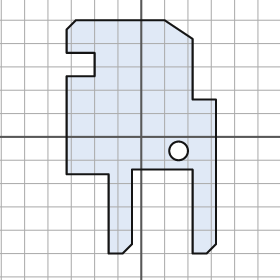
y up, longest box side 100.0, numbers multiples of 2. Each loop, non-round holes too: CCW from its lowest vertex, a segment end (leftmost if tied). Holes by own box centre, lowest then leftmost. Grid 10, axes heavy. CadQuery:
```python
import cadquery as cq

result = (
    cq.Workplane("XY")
    .moveTo(-14.0, -50.0)
    .lineTo(-8.0, -50.0)
    .lineTo(-4.0, -46.0)
    .lineTo(-4.0, -14.0)
    .lineTo(22.0, -14.0)
    .lineTo(22.0, -50.0)
    .lineTo(28.0, -50.0)
    .lineTo(32.0, -46.0)
    .lineTo(32.0, 16.0)
    .lineTo(22.0, 16.0)
    .lineTo(22.0, 42.0)
    .lineTo(10.0, 50.0)
    .lineTo(-28.0, 50.0)
    .lineTo(-32.0, 46.0)
    .lineTo(-32.0, 36.0)
    .lineTo(-20.0, 36.0)
    .lineTo(-20.0, 26.0)
    .lineTo(-32.0, 26.0)
    .lineTo(-32.0, -16.0)
    .lineTo(-14.0, -16.0)
    .close()
    .moveTo(16.0, -6.0)
    .circle(4.0)
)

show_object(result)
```